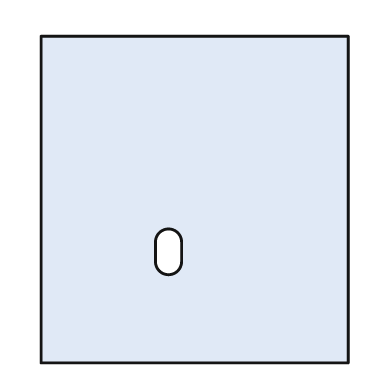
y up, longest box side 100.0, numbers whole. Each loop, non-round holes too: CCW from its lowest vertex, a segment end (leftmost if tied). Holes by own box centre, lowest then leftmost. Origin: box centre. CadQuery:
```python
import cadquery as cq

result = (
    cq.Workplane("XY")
    .moveTo(-47.0, -50.0)
    .lineTo(47.0, -50.0)
    .lineTo(47.0, 50.0)
    .lineTo(-47.0, 50.0)
    .close()
    .moveTo(-12.0, -19.0)
    .threePointArc((-8.0, -23.0), (-4.0, -19.0))
    .lineTo(-4.0, -13.0)
    .threePointArc((-8.0, -9.0), (-12.0, -13.0))
    .close()
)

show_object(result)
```